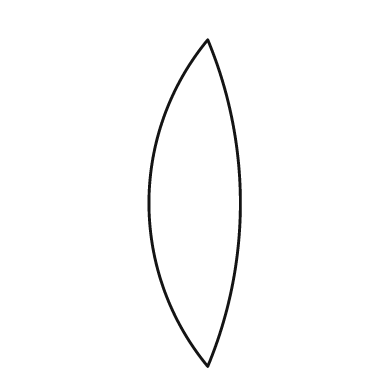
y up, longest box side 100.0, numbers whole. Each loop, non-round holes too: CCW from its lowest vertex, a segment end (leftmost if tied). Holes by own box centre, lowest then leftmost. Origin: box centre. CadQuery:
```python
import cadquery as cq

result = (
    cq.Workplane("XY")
    .moveTo(4.0, -50.0)
    .threePointArc((14.0, 0.0), (4.0, 50.0))
    .threePointArc((-14.0, 0.0), (4.0, -50.0))
    .close()
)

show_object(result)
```